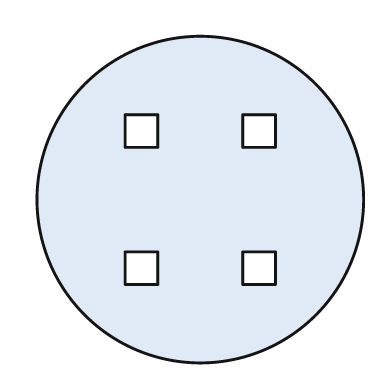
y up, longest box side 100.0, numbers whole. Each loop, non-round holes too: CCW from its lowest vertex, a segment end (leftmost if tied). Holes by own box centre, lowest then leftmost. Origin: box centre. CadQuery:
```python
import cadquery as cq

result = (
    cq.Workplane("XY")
    .moveTo(0.0, 0.0)
    .circle(50.0)
    .moveTo(-23.0, -26.0)
    .lineTo(-13.0, -26.0)
    .lineTo(-13.0, -16.0)
    .lineTo(-23.0, -16.0)
    .close()
    .moveTo(13.0, -26.0)
    .lineTo(23.0, -26.0)
    .lineTo(23.0, -16.0)
    .lineTo(13.0, -16.0)
    .close()
    .moveTo(-23.0, 16.0)
    .lineTo(-13.0, 16.0)
    .lineTo(-13.0, 26.0)
    .lineTo(-23.0, 26.0)
    .close()
    .moveTo(13.0, 16.0)
    .lineTo(23.0, 16.0)
    .lineTo(23.0, 26.0)
    .lineTo(13.0, 26.0)
    .close()
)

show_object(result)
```